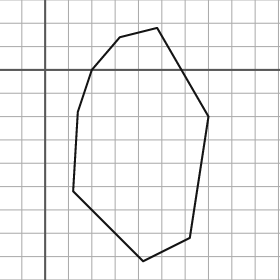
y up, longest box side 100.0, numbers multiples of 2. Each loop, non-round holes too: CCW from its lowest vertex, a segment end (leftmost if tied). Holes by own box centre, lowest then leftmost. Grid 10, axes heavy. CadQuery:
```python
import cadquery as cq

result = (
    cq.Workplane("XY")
    .moveTo(42.0, -82.0)
    .lineTo(62.0, -72.0)
    .lineTo(70.0, -20.0)
    .lineTo(48.0, 18.0)
    .lineTo(32.0, 14.0)
    .lineTo(20.0, 0.0)
    .lineTo(14.0, -18.0)
    .lineTo(12.0, -52.0)
    .close()
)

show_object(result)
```